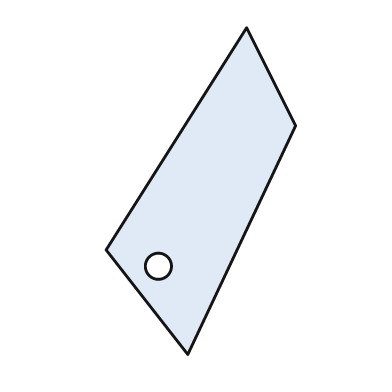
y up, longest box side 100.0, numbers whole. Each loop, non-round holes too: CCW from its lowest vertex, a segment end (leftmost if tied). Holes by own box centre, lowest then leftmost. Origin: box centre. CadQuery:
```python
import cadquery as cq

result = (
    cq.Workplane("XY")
    .moveTo(-4.0, -50.0)
    .lineTo(29.0, 20.0)
    .lineTo(14.0, 50.0)
    .lineTo(-29.0, -18.0)
    .close()
    .moveTo(-13.0, -23.0)
    .circle(4.0)
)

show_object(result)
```